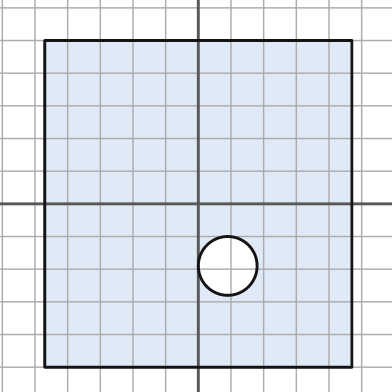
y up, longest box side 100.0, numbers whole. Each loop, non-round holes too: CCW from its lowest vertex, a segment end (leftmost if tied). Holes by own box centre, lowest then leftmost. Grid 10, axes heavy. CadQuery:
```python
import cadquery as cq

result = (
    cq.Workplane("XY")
    .moveTo(-47.0, -50.0)
    .lineTo(47.0, -50.0)
    .lineTo(47.0, 50.0)
    .lineTo(-47.0, 50.0)
    .close()
    .moveTo(9.0, -19.0)
    .circle(9.0)
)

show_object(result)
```